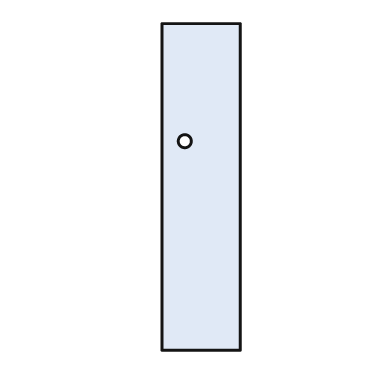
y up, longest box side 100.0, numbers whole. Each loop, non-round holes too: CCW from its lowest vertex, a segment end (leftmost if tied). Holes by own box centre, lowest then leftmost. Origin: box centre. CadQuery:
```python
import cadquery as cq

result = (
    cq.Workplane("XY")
    .moveTo(-12.0, -50.0)
    .lineTo(12.0, -50.0)
    .lineTo(12.0, 50.0)
    .lineTo(-12.0, 50.0)
    .close()
    .moveTo(-5.0, 14.0)
    .circle(2.0)
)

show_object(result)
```